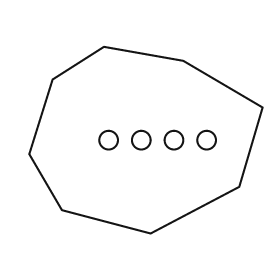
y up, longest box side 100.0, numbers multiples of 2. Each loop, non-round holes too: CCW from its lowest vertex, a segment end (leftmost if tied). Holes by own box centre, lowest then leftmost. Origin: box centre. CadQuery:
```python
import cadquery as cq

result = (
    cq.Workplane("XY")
    .moveTo(2.0, -40.0)
    .lineTo(40.0, -20.0)
    .lineTo(50.0, 14.0)
    .lineTo(16.0, 34.0)
    .lineTo(-18.0, 40.0)
    .lineTo(-40.0, 26.0)
    .lineTo(-50.0, -6.0)
    .lineTo(-36.0, -30.0)
    .close()
    .moveTo(-16.0, 0.0)
    .circle(4.0)
    .moveTo(-2.0, 0.0)
    .circle(4.0)
    .moveTo(12.0, 0.0)
    .circle(4.0)
    .moveTo(26.0, 0.0)
    .circle(4.0)
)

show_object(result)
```